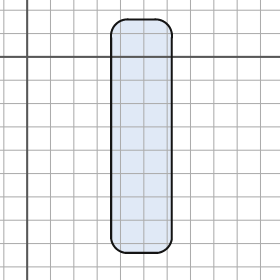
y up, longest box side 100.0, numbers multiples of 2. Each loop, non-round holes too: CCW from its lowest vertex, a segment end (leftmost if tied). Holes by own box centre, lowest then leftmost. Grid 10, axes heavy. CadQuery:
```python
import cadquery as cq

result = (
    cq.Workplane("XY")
    .moveTo(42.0, -84.0)
    .lineTo(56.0, -84.0)
    .threePointArc((60.0, -82.0), (62.0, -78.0))
    .lineTo(62.0, 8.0)
    .threePointArc((60.0, 14.0), (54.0, 16.0))
    .lineTo(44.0, 16.0)
    .threePointArc((38.0, 14.0), (36.0, 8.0))
    .lineTo(36.0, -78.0)
    .threePointArc((38.0, -82.0), (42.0, -84.0))
    .close()
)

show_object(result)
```